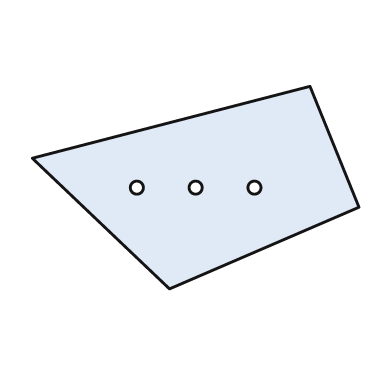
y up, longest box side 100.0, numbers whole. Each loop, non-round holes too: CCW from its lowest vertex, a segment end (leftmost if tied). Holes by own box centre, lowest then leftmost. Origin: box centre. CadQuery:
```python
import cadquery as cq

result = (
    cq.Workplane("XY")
    .moveTo(-8.0, -31.0)
    .lineTo(50.0, -6.0)
    .lineTo(35.0, 31.0)
    .lineTo(-50.0, 9.0)
    .close()
    .moveTo(-18.0, 0.0)
    .circle(2.0)
    .moveTo(0.0, 0.0)
    .circle(2.0)
    .moveTo(18.0, 0.0)
    .circle(2.0)
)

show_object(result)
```